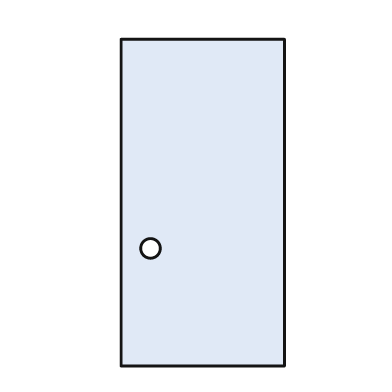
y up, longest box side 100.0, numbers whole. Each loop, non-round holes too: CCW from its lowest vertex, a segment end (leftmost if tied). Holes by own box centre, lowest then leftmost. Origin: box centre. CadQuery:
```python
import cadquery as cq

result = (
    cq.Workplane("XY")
    .moveTo(-25.0, -50.0)
    .lineTo(25.0, -50.0)
    .lineTo(25.0, 50.0)
    .lineTo(-25.0, 50.0)
    .close()
    .moveTo(-16.0, -14.0)
    .circle(3.0)
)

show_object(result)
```